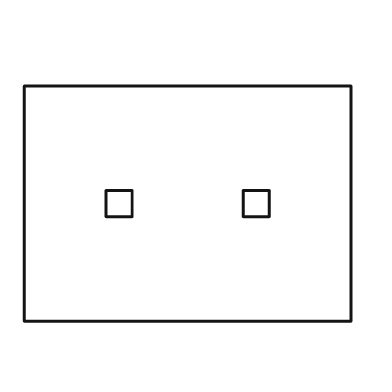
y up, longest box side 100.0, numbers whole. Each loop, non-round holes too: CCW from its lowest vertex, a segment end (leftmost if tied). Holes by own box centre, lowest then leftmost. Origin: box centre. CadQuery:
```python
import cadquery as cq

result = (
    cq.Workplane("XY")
    .moveTo(-50.0, -36.0)
    .lineTo(50.0, -36.0)
    .lineTo(50.0, 36.0)
    .lineTo(-50.0, 36.0)
    .close()
    .moveTo(-25.0, -4.0)
    .lineTo(-17.0, -4.0)
    .lineTo(-17.0, 4.0)
    .lineTo(-25.0, 4.0)
    .close()
    .moveTo(17.0, -4.0)
    .lineTo(25.0, -4.0)
    .lineTo(25.0, 4.0)
    .lineTo(17.0, 4.0)
    .close()
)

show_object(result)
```